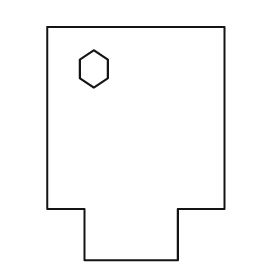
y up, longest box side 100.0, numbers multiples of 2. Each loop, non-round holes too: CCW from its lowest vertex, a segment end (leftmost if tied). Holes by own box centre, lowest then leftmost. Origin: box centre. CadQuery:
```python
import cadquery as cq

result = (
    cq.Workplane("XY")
    .moveTo(-22.0, -50.0)
    .lineTo(18.0, -50.0)
    .lineTo(18.0, -28.0)
    .lineTo(38.0, -28.0)
    .lineTo(38.0, 50.0)
    .lineTo(-38.0, 50.0)
    .lineTo(-38.0, -28.0)
    .lineTo(-22.0, -28.0)
    .close()
    .moveTo(-18.0, 24.0)
    .lineTo(-12.0, 28.0)
    .lineTo(-12.0, 36.0)
    .lineTo(-18.0, 40.0)
    .lineTo(-24.0, 36.0)
    .lineTo(-24.0, 28.0)
    .close()
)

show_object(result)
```